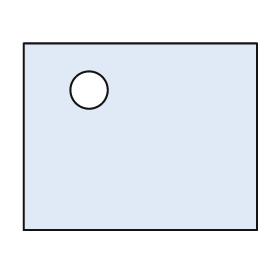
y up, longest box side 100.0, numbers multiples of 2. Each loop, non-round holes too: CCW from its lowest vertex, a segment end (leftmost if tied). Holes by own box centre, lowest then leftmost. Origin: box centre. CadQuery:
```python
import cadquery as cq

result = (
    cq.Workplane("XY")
    .moveTo(-50.0, -40.0)
    .lineTo(50.0, -40.0)
    .lineTo(50.0, 40.0)
    .lineTo(-50.0, 40.0)
    .close()
    .moveTo(-22.0, 20.0)
    .circle(8.0)
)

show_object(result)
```